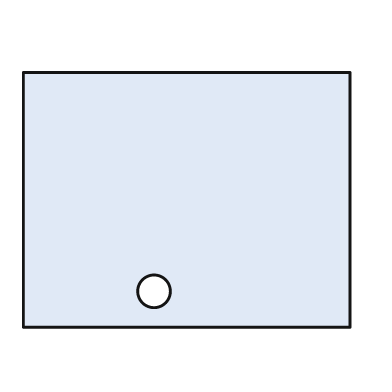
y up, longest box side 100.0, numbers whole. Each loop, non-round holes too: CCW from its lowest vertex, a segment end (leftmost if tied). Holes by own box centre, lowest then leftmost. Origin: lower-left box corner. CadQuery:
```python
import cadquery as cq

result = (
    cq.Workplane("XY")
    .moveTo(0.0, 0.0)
    .lineTo(100.0, 0.0)
    .lineTo(100.0, 78.0)
    .lineTo(0.0, 78.0)
    .close()
    .moveTo(40.0, 11.0)
    .circle(5.0)
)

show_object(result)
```